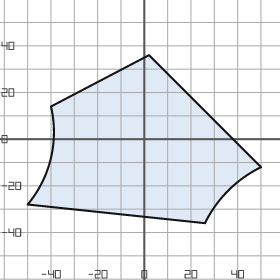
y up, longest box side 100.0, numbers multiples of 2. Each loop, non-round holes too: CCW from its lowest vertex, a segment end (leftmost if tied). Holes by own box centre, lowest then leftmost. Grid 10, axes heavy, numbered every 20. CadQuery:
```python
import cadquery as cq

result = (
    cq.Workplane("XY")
    .moveTo(26.0, -36.0)
    .threePointArc((36.0, -22.0), (50.0, -12.0))
    .lineTo(2.0, 36.0)
    .lineTo(-40.0, 14.0)
    .threePointArc((-40.0, -8.0), (-50.0, -28.0))
    .close()
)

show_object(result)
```